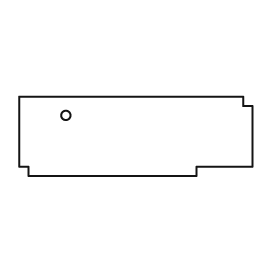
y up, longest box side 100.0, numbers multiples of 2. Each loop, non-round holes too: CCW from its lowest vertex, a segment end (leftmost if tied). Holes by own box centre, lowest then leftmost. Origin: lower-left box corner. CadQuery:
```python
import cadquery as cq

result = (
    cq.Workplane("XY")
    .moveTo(4.0, 0.0)
    .lineTo(76.0, 0.0)
    .lineTo(76.0, 4.0)
    .lineTo(100.0, 4.0)
    .lineTo(100.0, 30.0)
    .lineTo(96.0, 30.0)
    .lineTo(96.0, 34.0)
    .lineTo(0.0, 34.0)
    .lineTo(0.0, 4.0)
    .lineTo(4.0, 4.0)
    .close()
    .moveTo(20.0, 26.0)
    .circle(2.0)
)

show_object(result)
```